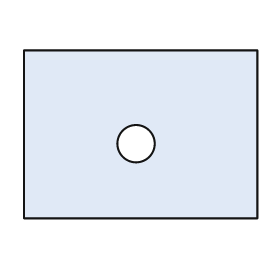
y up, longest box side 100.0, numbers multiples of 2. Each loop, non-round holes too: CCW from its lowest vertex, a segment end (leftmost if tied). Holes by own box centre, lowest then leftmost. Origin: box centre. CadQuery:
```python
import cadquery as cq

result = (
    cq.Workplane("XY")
    .moveTo(-50.0, -36.0)
    .lineTo(50.0, -36.0)
    .lineTo(50.0, 36.0)
    .lineTo(-50.0, 36.0)
    .close()
    .moveTo(-2.0, -4.0)
    .circle(8.0)
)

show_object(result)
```